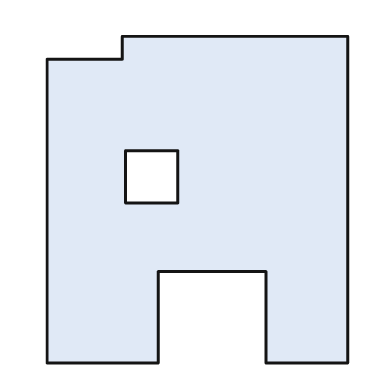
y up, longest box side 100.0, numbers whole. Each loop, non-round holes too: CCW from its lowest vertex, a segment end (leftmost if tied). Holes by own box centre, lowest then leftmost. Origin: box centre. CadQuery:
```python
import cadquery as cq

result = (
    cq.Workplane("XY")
    .moveTo(-46.0, -50.0)
    .lineTo(-12.0, -50.0)
    .lineTo(-12.0, -22.0)
    .lineTo(21.0, -22.0)
    .lineTo(21.0, -50.0)
    .lineTo(46.0, -50.0)
    .lineTo(46.0, 50.0)
    .lineTo(-23.0, 50.0)
    .lineTo(-23.0, 43.0)
    .lineTo(-46.0, 43.0)
    .close()
    .moveTo(-22.0, -1.0)
    .lineTo(-6.0, -1.0)
    .lineTo(-6.0, 15.0)
    .lineTo(-22.0, 15.0)
    .close()
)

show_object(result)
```